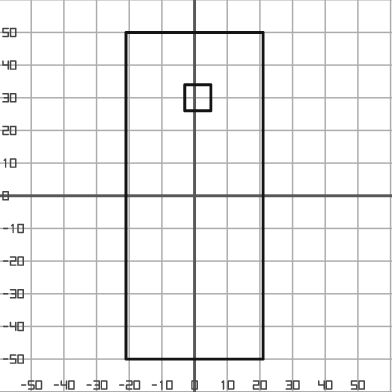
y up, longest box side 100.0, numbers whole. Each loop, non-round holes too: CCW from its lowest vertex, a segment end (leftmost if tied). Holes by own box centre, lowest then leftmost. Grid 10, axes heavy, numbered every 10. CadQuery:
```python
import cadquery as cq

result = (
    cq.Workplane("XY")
    .moveTo(-21.0, -50.0)
    .lineTo(21.0, -50.0)
    .lineTo(21.0, 50.0)
    .lineTo(-21.0, 50.0)
    .close()
    .moveTo(-3.0, 26.0)
    .lineTo(5.0, 26.0)
    .lineTo(5.0, 34.0)
    .lineTo(-3.0, 34.0)
    .close()
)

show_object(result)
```